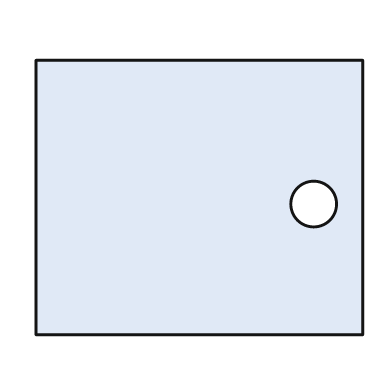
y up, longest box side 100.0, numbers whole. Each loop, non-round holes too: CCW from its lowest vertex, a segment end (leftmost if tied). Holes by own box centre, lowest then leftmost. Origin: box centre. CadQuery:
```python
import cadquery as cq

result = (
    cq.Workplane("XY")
    .moveTo(-50.0, -42.0)
    .lineTo(50.0, -42.0)
    .lineTo(50.0, 42.0)
    .lineTo(-50.0, 42.0)
    .close()
    .moveTo(35.0, -2.0)
    .circle(7.0)
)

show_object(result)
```